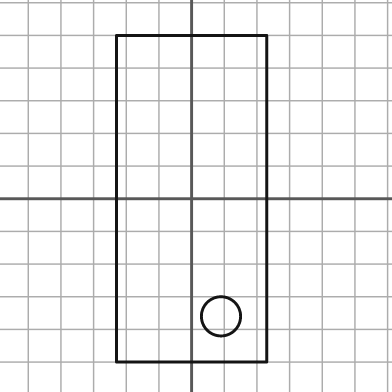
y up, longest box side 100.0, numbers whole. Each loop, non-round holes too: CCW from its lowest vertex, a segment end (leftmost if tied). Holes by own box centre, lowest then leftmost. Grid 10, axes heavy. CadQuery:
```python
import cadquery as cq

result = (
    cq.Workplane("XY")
    .moveTo(-23.0, -50.0)
    .lineTo(23.0, -50.0)
    .lineTo(23.0, 50.0)
    .lineTo(-23.0, 50.0)
    .close()
    .moveTo(9.0, -36.0)
    .circle(6.0)
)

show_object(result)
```